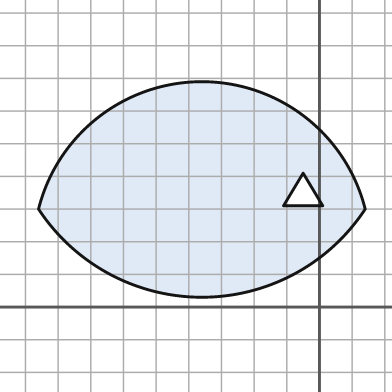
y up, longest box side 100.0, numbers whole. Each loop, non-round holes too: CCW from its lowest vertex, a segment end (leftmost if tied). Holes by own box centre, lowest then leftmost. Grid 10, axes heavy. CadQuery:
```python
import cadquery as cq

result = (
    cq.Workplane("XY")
    .moveTo(-86.0, 30.0)
    .threePointArc((-36.0, 3.0), (14.0, 30.0))
    .threePointArc((-36.0, 69.0), (-86.0, 30.0))
    .close()
    .moveTo(-11.0, 31.0)
    .lineTo(1.0, 31.0)
    .lineTo(-5.0, 41.0)
    .close()
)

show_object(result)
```